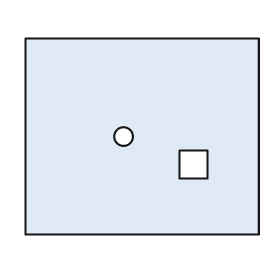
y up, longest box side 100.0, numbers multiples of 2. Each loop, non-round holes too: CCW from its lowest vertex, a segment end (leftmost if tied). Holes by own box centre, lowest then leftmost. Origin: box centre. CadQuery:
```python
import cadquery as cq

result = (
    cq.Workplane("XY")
    .moveTo(-50.0, -42.0)
    .lineTo(50.0, -42.0)
    .lineTo(50.0, 42.0)
    .lineTo(-50.0, 42.0)
    .close()
    .moveTo(16.0, -18.0)
    .lineTo(28.0, -18.0)
    .lineTo(28.0, -6.0)
    .lineTo(16.0, -6.0)
    .close()
    .moveTo(-8.0, 0.0)
    .circle(4.0)
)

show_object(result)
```